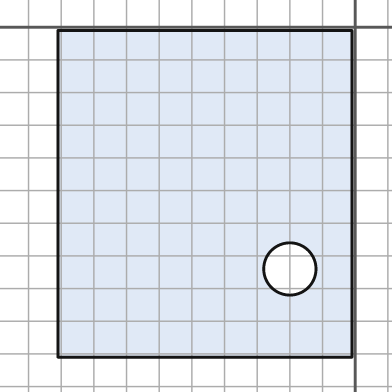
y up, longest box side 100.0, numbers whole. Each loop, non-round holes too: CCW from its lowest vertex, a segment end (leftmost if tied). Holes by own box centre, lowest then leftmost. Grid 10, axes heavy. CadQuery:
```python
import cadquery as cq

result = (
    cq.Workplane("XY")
    .moveTo(-91.0, -101.0)
    .lineTo(-1.0, -101.0)
    .lineTo(-1.0, -1.0)
    .lineTo(-91.0, -1.0)
    .close()
    .moveTo(-20.0, -74.0)
    .circle(8.0)
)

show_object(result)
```